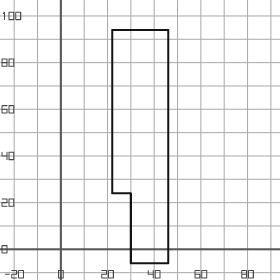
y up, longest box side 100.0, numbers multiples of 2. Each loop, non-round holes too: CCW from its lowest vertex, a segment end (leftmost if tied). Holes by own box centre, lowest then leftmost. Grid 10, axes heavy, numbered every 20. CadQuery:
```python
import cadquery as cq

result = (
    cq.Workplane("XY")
    .moveTo(30.0, -6.0)
    .lineTo(46.0, -6.0)
    .lineTo(46.0, 94.0)
    .lineTo(22.0, 94.0)
    .lineTo(22.0, 24.0)
    .lineTo(30.0, 24.0)
    .close()
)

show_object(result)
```